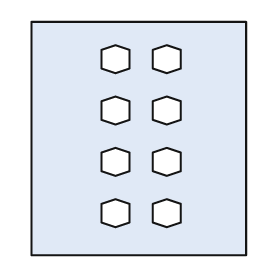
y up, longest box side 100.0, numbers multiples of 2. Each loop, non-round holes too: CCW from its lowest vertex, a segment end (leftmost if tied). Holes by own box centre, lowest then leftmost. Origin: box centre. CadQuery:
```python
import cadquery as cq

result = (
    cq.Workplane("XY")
    .moveTo(-46.0, -50.0)
    .lineTo(46.0, -50.0)
    .lineTo(46.0, 50.0)
    .lineTo(-46.0, 50.0)
    .close()
    .moveTo(-10.0, -38.0)
    .lineTo(-4.0, -36.0)
    .lineTo(-4.0, -28.0)
    .lineTo(-10.0, -26.0)
    .lineTo(-16.0, -28.0)
    .lineTo(-16.0, -36.0)
    .close()
    .moveTo(12.0, -38.0)
    .lineTo(18.0, -36.0)
    .lineTo(18.0, -28.0)
    .lineTo(12.0, -26.0)
    .lineTo(6.0, -28.0)
    .lineTo(6.0, -36.0)
    .close()
    .moveTo(-10.0, -16.0)
    .lineTo(-4.0, -14.0)
    .lineTo(-4.0, -6.0)
    .lineTo(-10.0, -4.0)
    .lineTo(-16.0, -6.0)
    .lineTo(-16.0, -14.0)
    .close()
    .moveTo(12.0, -16.0)
    .lineTo(18.0, -14.0)
    .lineTo(18.0, -6.0)
    .lineTo(12.0, -4.0)
    .lineTo(6.0, -6.0)
    .lineTo(6.0, -14.0)
    .close()
    .moveTo(-10.0, 6.0)
    .lineTo(-4.0, 8.0)
    .lineTo(-4.0, 16.0)
    .lineTo(-10.0, 18.0)
    .lineTo(-16.0, 16.0)
    .lineTo(-16.0, 8.0)
    .close()
    .moveTo(12.0, 6.0)
    .lineTo(18.0, 8.0)
    .lineTo(18.0, 16.0)
    .lineTo(12.0, 18.0)
    .lineTo(6.0, 16.0)
    .lineTo(6.0, 8.0)
    .close()
    .moveTo(-10.0, 28.0)
    .lineTo(-4.0, 30.0)
    .lineTo(-4.0, 38.0)
    .lineTo(-10.0, 40.0)
    .lineTo(-16.0, 38.0)
    .lineTo(-16.0, 30.0)
    .close()
    .moveTo(12.0, 28.0)
    .lineTo(18.0, 30.0)
    .lineTo(18.0, 38.0)
    .lineTo(12.0, 40.0)
    .lineTo(6.0, 38.0)
    .lineTo(6.0, 30.0)
    .close()
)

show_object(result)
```